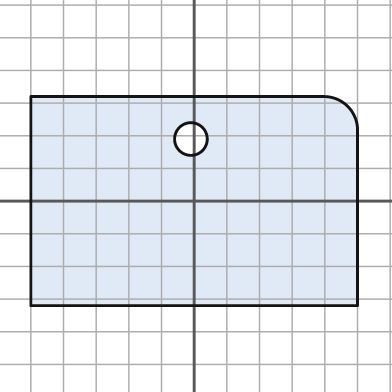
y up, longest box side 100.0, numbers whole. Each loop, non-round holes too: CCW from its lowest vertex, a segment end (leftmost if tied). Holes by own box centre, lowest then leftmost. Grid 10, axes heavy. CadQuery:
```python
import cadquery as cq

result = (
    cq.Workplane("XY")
    .moveTo(-50.0, -32.0)
    .lineTo(50.0, -32.0)
    .lineTo(50.0, 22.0)
    .threePointArc((47.0, 29.0), (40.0, 32.0))
    .lineTo(-50.0, 32.0)
    .close()
    .moveTo(-1.0, 19.0)
    .circle(5.0)
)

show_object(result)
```